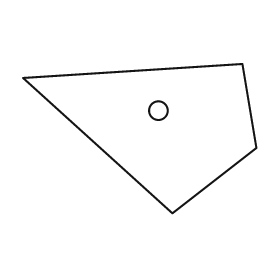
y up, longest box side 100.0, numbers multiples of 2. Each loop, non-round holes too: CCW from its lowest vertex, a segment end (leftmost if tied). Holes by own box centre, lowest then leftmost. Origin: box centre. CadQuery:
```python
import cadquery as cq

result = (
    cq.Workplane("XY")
    .moveTo(14.0, -32.0)
    .lineTo(50.0, -4.0)
    .lineTo(44.0, 32.0)
    .lineTo(-50.0, 26.0)
    .close()
    .moveTo(8.0, 12.0)
    .circle(4.0)
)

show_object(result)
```